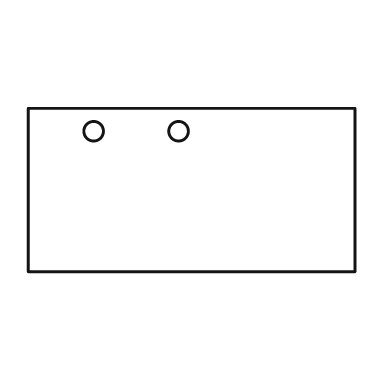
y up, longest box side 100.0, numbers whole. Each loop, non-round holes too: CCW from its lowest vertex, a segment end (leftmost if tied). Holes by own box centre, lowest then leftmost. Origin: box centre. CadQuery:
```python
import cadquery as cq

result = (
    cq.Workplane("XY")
    .moveTo(-50.0, -25.0)
    .lineTo(50.0, -25.0)
    .lineTo(50.0, 25.0)
    .lineTo(-50.0, 25.0)
    .close()
    .moveTo(-30.0, 18.0)
    .circle(3.0)
    .moveTo(-4.0, 18.0)
    .circle(3.0)
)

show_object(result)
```